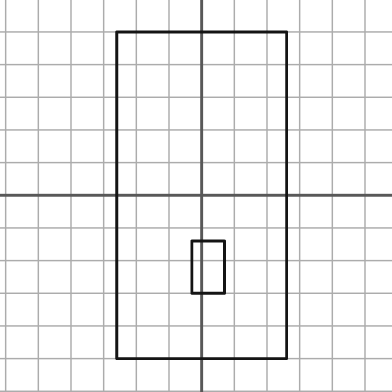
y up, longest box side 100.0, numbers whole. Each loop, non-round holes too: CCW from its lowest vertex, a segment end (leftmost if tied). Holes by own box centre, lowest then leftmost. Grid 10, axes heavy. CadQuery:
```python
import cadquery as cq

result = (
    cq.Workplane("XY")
    .moveTo(-26.0, -50.0)
    .lineTo(26.0, -50.0)
    .lineTo(26.0, 50.0)
    .lineTo(-26.0, 50.0)
    .close()
    .moveTo(-3.0, -30.0)
    .lineTo(7.0, -30.0)
    .lineTo(7.0, -14.0)
    .lineTo(-3.0, -14.0)
    .close()
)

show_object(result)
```